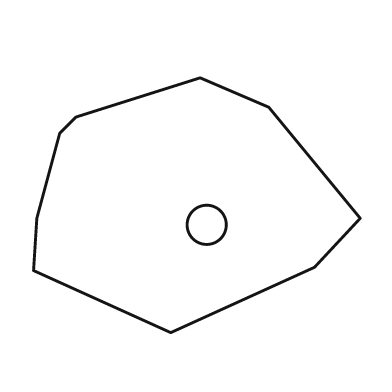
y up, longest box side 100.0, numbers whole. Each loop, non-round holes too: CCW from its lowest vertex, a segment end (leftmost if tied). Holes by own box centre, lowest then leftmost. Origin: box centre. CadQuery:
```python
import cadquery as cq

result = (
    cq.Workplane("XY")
    .moveTo(-8.0, -39.0)
    .lineTo(36.0, -19.0)
    .lineTo(50.0, -4.0)
    .lineTo(22.0, 30.0)
    .lineTo(1.0, 39.0)
    .lineTo(-37.0, 27.0)
    .lineTo(-42.0, 22.0)
    .lineTo(-49.0, -4.0)
    .lineTo(-50.0, -20.0)
    .close()
    .moveTo(3.0, -6.0)
    .circle(6.0)
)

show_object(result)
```